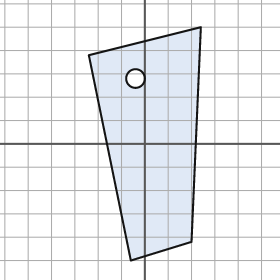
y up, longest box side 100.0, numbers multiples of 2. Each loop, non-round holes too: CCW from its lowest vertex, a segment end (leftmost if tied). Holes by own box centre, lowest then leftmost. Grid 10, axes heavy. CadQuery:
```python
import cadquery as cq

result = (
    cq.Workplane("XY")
    .moveTo(-6.0, -50.0)
    .lineTo(20.0, -42.0)
    .lineTo(24.0, 50.0)
    .lineTo(-24.0, 38.0)
    .close()
    .moveTo(-4.0, 28.0)
    .circle(4.0)
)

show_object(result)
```